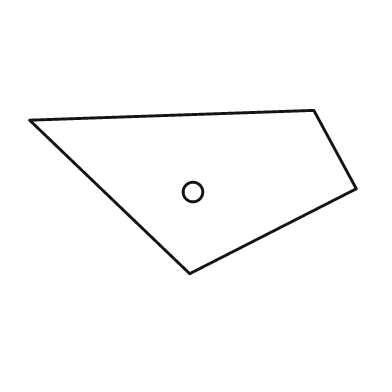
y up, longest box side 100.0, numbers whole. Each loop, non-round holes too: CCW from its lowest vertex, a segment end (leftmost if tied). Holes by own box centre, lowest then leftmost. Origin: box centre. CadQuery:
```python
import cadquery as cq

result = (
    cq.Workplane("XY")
    .moveTo(-1.0, -25.0)
    .lineTo(50.0, 1.0)
    .lineTo(37.0, 25.0)
    .lineTo(-50.0, 22.0)
    .close()
    .moveTo(0.0, 0.0)
    .circle(3.0)
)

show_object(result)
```